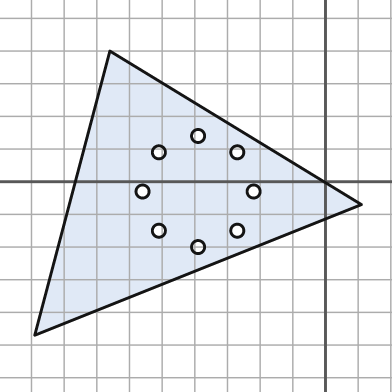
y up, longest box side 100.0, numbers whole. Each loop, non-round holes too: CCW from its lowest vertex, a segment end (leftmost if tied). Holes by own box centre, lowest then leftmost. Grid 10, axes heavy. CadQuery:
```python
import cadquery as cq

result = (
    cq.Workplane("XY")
    .moveTo(-89.0, -47.0)
    .lineTo(11.0, -7.0)
    .lineTo(-66.0, 40.0)
    .close()
    .moveTo(-39.0, -20.0)
    .circle(2.0)
    .moveTo(-51.0, -15.0)
    .circle(2.0)
    .moveTo(-27.0, -15.0)
    .circle(2.0)
    .moveTo(-56.0, -3.0)
    .circle(2.0)
    .moveTo(-22.0, -3.0)
    .circle(2.0)
    .moveTo(-51.0, 9.0)
    .circle(2.0)
    .moveTo(-27.0, 9.0)
    .circle(2.0)
    .moveTo(-39.0, 14.0)
    .circle(2.0)
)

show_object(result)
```